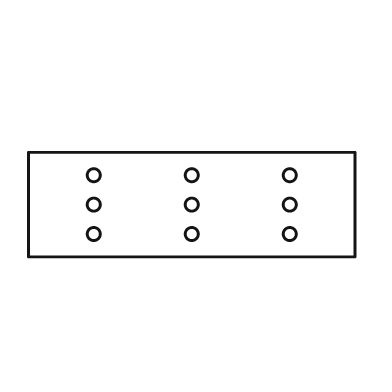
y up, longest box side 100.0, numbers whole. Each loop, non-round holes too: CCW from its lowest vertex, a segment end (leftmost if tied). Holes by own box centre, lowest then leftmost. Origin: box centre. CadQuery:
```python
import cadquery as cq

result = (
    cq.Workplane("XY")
    .moveTo(-50.0, -16.0)
    .lineTo(50.0, -16.0)
    .lineTo(50.0, 16.0)
    .lineTo(-50.0, 16.0)
    .close()
    .moveTo(-30.0, -9.0)
    .circle(2.0)
    .moveTo(0.0, -9.0)
    .circle(2.0)
    .moveTo(30.0, -9.0)
    .circle(2.0)
    .moveTo(-30.0, 0.0)
    .circle(2.0)
    .moveTo(0.0, 0.0)
    .circle(2.0)
    .moveTo(30.0, 0.0)
    .circle(2.0)
    .moveTo(-30.0, 9.0)
    .circle(2.0)
    .moveTo(0.0, 9.0)
    .circle(2.0)
    .moveTo(30.0, 9.0)
    .circle(2.0)
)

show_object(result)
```